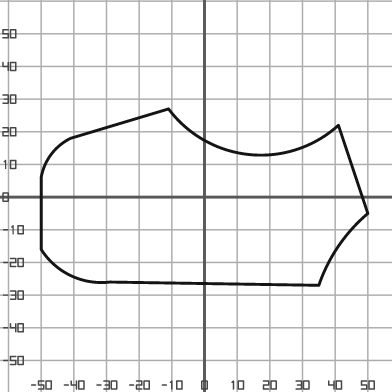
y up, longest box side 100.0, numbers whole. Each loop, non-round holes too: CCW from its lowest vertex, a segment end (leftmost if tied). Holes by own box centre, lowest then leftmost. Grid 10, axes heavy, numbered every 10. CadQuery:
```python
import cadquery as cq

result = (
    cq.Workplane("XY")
    .moveTo(35.0, -27.0)
    .threePointArc((41.0, -15.0), (50.0, -5.0))
    .lineTo(41.0, 22.0)
    .threePointArc((14.0, 13.0), (-11.0, 27.0))
    .lineTo(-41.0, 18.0)
    .threePointArc((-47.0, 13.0), (-50.0, 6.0))
    .lineTo(-50.0, -16.0)
    .threePointArc((-41.0, -24.0), (-29.0, -26.0))
    .close()
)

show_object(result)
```